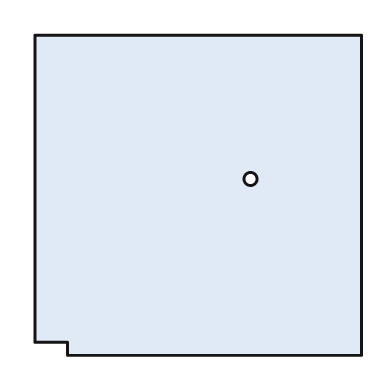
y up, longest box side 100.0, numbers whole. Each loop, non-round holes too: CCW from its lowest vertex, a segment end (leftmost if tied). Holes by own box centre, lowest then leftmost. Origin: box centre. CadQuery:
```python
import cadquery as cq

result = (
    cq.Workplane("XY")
    .moveTo(-40.0, -49.0)
    .lineTo(50.0, -49.0)
    .lineTo(50.0, 49.0)
    .lineTo(-50.0, 49.0)
    .lineTo(-50.0, -45.0)
    .lineTo(-40.0, -45.0)
    .close()
    .moveTo(16.0, 5.0)
    .circle(2.0)
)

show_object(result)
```